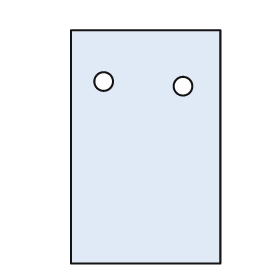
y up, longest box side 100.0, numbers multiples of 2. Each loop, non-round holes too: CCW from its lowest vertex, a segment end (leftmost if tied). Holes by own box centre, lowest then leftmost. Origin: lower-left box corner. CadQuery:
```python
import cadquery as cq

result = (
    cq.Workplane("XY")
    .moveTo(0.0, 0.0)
    .lineTo(64.0, 0.0)
    .lineTo(64.0, 100.0)
    .lineTo(0.0, 100.0)
    .close()
    .moveTo(48.0, 76.0)
    .circle(4.0)
    .moveTo(14.0, 78.0)
    .circle(4.0)
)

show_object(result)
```